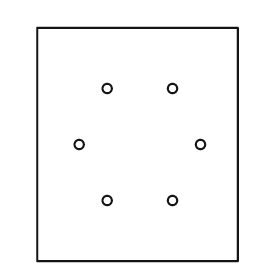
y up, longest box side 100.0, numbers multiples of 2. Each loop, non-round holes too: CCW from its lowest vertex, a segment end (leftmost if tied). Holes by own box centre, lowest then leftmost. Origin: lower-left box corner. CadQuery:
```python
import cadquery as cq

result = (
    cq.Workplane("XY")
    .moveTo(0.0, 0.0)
    .lineTo(86.0, 0.0)
    .lineTo(86.0, 100.0)
    .lineTo(0.0, 100.0)
    .close()
    .moveTo(30.0, 26.0)
    .circle(2.0)
    .moveTo(58.0, 26.0)
    .circle(2.0)
    .moveTo(18.0, 50.0)
    .circle(2.0)
    .moveTo(70.0, 50.0)
    .circle(2.0)
    .moveTo(30.0, 74.0)
    .circle(2.0)
    .moveTo(58.0, 74.0)
    .circle(2.0)
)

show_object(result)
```